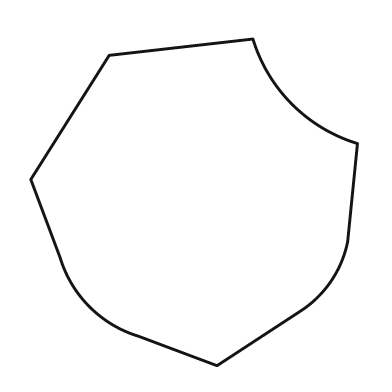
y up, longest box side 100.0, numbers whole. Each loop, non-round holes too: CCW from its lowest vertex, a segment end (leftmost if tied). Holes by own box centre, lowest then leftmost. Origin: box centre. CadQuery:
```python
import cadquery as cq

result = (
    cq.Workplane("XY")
    .moveTo(7.0, -50.0)
    .lineTo(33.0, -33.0)
    .threePointArc((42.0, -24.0), (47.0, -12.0))
    .lineTo(50.0, 18.0)
    .threePointArc((30.0, 30.0), (18.0, 50.0))
    .lineTo(-26.0, 45.0)
    .lineTo(-50.0, 7.0)
    .lineTo(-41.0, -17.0)
    .threePointArc((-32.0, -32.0), (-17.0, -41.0))
    .close()
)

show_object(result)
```